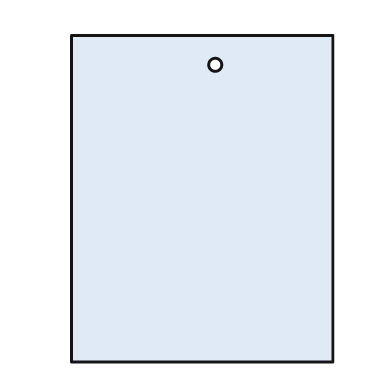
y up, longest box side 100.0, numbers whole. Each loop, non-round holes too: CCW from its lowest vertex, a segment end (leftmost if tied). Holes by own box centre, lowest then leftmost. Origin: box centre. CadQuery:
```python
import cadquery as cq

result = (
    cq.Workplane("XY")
    .moveTo(-40.0, -50.0)
    .lineTo(40.0, -50.0)
    .lineTo(40.0, 50.0)
    .lineTo(-40.0, 50.0)
    .close()
    .moveTo(4.0, 41.0)
    .circle(2.0)
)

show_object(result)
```